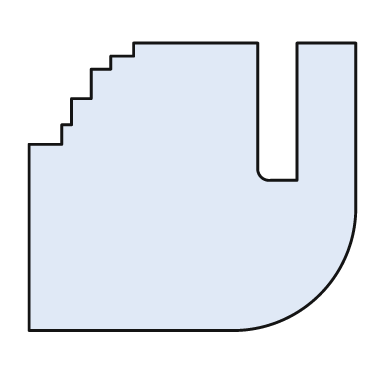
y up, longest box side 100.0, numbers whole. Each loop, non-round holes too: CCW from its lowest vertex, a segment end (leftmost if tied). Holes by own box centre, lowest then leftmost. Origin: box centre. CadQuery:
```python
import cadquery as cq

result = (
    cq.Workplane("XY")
    .moveTo(-50.0, -44.0)
    .lineTo(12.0, -44.0)
    .threePointArc((39.0, -33.0), (50.0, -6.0))
    .lineTo(50.0, 44.0)
    .lineTo(32.0, 44.0)
    .lineTo(32.0, 2.0)
    .lineTo(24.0, 2.0)
    .threePointArc((21.0, 3.0), (20.0, 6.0))
    .lineTo(20.0, 44.0)
    .lineTo(-18.0, 44.0)
    .lineTo(-18.0, 40.0)
    .lineTo(-25.0, 40.0)
    .lineTo(-25.0, 36.0)
    .lineTo(-31.0, 36.0)
    .lineTo(-31.0, 27.0)
    .lineTo(-37.0, 27.0)
    .lineTo(-37.0, 19.0)
    .lineTo(-40.0, 19.0)
    .lineTo(-40.0, 13.0)
    .lineTo(-50.0, 13.0)
    .close()
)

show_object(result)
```